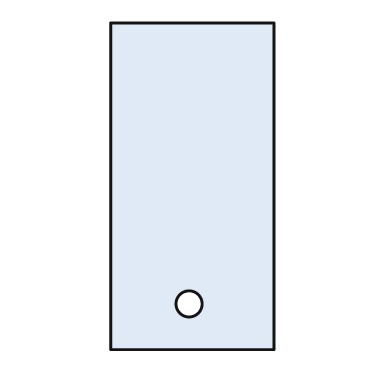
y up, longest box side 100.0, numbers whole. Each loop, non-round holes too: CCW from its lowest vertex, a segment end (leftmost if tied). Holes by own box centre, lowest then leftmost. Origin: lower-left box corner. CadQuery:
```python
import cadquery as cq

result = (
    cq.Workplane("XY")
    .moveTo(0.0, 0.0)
    .lineTo(50.0, 0.0)
    .lineTo(50.0, 100.0)
    .lineTo(0.0, 100.0)
    .close()
    .moveTo(24.0, 14.0)
    .circle(4.0)
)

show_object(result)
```